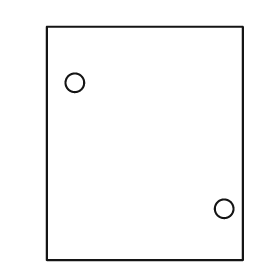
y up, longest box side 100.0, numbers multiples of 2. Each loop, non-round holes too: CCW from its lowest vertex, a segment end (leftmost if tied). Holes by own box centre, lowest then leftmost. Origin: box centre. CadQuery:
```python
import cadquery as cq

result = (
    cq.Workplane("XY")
    .moveTo(-42.0, -50.0)
    .lineTo(42.0, -50.0)
    .lineTo(42.0, 50.0)
    .lineTo(-42.0, 50.0)
    .close()
    .moveTo(34.0, -28.0)
    .circle(4.0)
    .moveTo(-30.0, 26.0)
    .circle(4.0)
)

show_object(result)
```